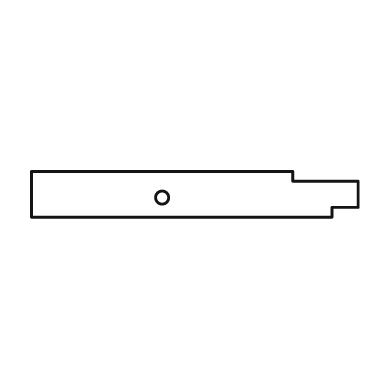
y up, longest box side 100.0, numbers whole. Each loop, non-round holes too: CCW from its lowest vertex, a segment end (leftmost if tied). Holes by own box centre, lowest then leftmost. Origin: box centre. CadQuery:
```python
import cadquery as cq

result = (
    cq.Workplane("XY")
    .moveTo(-50.0, -7.0)
    .lineTo(42.0, -7.0)
    .lineTo(42.0, -4.0)
    .lineTo(50.0, -4.0)
    .lineTo(50.0, 4.0)
    .lineTo(30.0, 4.0)
    .lineTo(30.0, 7.0)
    .lineTo(-50.0, 7.0)
    .close()
    .moveTo(-10.0, -1.0)
    .circle(2.0)
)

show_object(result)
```